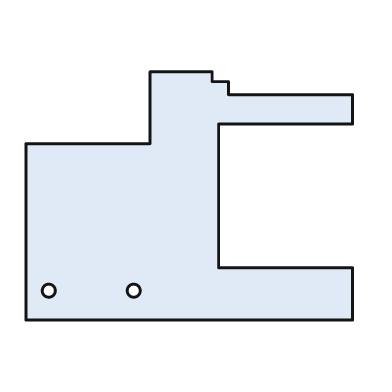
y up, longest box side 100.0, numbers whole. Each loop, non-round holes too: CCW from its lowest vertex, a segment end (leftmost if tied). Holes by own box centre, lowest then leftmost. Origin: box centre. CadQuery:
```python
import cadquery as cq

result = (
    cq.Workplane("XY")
    .moveTo(-50.0, -38.0)
    .lineTo(50.0, -38.0)
    .lineTo(50.0, -22.0)
    .lineTo(9.0, -22.0)
    .lineTo(9.0, 22.0)
    .lineTo(50.0, 22.0)
    .lineTo(50.0, 31.0)
    .lineTo(12.0, 31.0)
    .lineTo(12.0, 35.0)
    .lineTo(7.0, 35.0)
    .lineTo(7.0, 38.0)
    .lineTo(-12.0, 38.0)
    .lineTo(-12.0, 16.0)
    .lineTo(-50.0, 16.0)
    .close()
    .moveTo(-43.0, -29.0)
    .circle(2.0)
    .moveTo(-17.0, -29.0)
    .circle(2.0)
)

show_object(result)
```